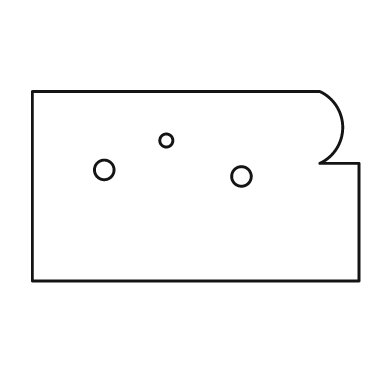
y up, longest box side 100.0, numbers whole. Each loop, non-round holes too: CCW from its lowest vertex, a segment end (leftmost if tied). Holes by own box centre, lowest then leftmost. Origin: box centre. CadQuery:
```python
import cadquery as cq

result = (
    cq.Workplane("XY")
    .moveTo(-50.0, -29.0)
    .lineTo(50.0, -29.0)
    .lineTo(50.0, 7.0)
    .lineTo(38.0, 7.0)
    .threePointArc((45.0, 18.0), (38.0, 29.0))
    .lineTo(-50.0, 29.0)
    .close()
    .moveTo(14.0, 3.0)
    .circle(3.0)
    .moveTo(-28.0, 5.0)
    .circle(3.0)
    .moveTo(-9.0, 14.0)
    .circle(2.0)
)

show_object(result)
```